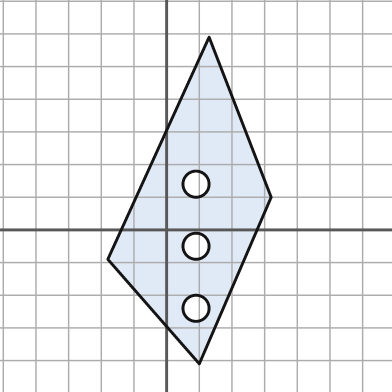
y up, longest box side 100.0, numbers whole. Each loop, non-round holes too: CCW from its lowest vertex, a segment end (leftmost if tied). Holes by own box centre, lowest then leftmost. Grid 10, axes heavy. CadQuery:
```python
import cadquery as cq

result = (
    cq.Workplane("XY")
    .moveTo(10.0, -41.0)
    .lineTo(32.0, 10.0)
    .lineTo(13.0, 59.0)
    .lineTo(-18.0, -9.0)
    .close()
    .moveTo(9.0, -24.0)
    .circle(4.0)
    .moveTo(9.0, -5.0)
    .circle(4.0)
    .moveTo(9.0, 14.0)
    .circle(4.0)
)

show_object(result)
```